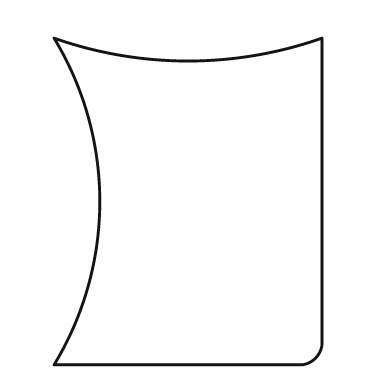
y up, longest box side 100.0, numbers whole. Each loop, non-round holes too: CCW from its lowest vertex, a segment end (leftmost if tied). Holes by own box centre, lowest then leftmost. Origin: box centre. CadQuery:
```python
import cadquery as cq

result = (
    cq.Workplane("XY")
    .moveTo(-41.0, -50.0)
    .lineTo(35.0, -50.0)
    .threePointArc((39.0, -48.0), (41.0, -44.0))
    .lineTo(41.0, 50.0)
    .threePointArc((0.0, 43.0), (-41.0, 50.0))
    .threePointArc((-27.0, 0.0), (-41.0, -50.0))
    .close()
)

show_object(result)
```